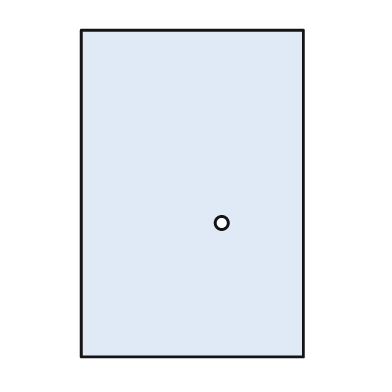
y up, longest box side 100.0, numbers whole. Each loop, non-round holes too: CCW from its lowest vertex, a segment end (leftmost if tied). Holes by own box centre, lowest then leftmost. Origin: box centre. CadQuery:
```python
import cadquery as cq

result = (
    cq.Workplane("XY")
    .moveTo(-34.0, -50.0)
    .lineTo(34.0, -50.0)
    .lineTo(34.0, 50.0)
    .lineTo(-34.0, 50.0)
    .close()
    .moveTo(9.0, -9.0)
    .circle(2.0)
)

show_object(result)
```